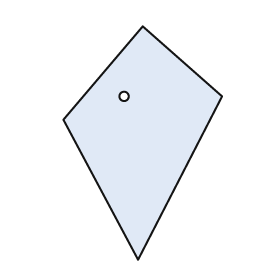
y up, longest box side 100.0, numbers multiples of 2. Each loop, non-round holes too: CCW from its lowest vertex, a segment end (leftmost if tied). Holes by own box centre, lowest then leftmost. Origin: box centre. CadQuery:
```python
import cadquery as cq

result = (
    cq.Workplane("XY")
    .moveTo(-2.0, -50.0)
    .lineTo(34.0, 20.0)
    .lineTo(0.0, 50.0)
    .lineTo(-34.0, 10.0)
    .close()
    .moveTo(-8.0, 20.0)
    .circle(2.0)
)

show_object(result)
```